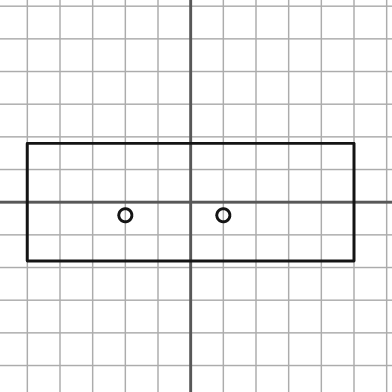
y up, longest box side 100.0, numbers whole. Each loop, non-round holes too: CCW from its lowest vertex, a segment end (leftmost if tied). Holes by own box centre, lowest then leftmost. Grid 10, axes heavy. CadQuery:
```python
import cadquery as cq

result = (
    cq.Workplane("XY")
    .moveTo(-50.0, -18.0)
    .lineTo(50.0, -18.0)
    .lineTo(50.0, 18.0)
    .lineTo(-50.0, 18.0)
    .close()
    .moveTo(-20.0, -4.0)
    .circle(2.0)
    .moveTo(10.0, -4.0)
    .circle(2.0)
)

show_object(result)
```